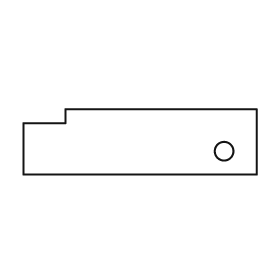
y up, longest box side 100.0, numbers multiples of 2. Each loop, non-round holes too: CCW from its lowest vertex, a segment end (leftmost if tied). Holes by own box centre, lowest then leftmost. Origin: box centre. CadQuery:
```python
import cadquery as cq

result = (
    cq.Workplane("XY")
    .moveTo(-50.0, -14.0)
    .lineTo(50.0, -14.0)
    .lineTo(50.0, 14.0)
    .lineTo(-32.0, 14.0)
    .lineTo(-32.0, 8.0)
    .lineTo(-50.0, 8.0)
    .close()
    .moveTo(36.0, -4.0)
    .circle(4.0)
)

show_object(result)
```